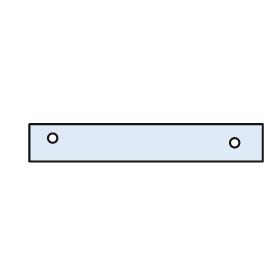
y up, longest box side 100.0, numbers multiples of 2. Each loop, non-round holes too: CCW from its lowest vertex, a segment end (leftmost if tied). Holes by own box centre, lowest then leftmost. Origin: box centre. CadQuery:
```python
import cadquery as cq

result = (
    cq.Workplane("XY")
    .moveTo(-50.0, -8.0)
    .lineTo(50.0, -8.0)
    .lineTo(50.0, 8.0)
    .lineTo(-50.0, 8.0)
    .close()
    .moveTo(38.0, 0.0)
    .circle(2.0)
    .moveTo(-40.0, 2.0)
    .circle(2.0)
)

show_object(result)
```